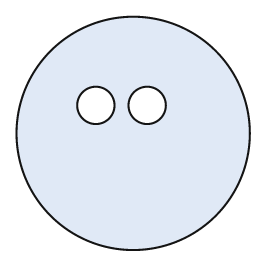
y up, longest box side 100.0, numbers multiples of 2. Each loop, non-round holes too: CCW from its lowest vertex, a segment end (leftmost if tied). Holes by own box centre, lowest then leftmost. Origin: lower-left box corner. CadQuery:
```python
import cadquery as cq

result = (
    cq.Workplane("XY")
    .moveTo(50.0, 50.0)
    .circle(50.0)
    .moveTo(34.0, 62.0)
    .circle(8.0)
    .moveTo(56.0, 62.0)
    .circle(8.0)
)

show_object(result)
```